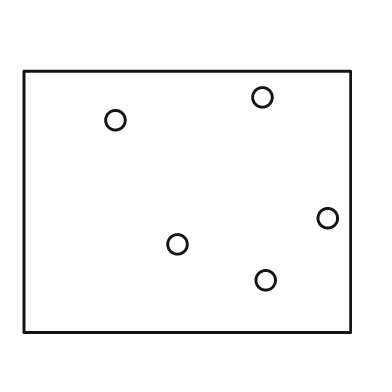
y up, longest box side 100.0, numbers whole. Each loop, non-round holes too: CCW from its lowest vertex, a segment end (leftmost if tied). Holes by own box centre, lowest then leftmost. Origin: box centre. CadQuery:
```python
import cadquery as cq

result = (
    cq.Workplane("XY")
    .moveTo(-50.0, -40.0)
    .lineTo(50.0, -40.0)
    .lineTo(50.0, 40.0)
    .lineTo(-50.0, 40.0)
    .close()
    .moveTo(24.0, -24.0)
    .circle(3.0)
    .moveTo(-3.0, -13.0)
    .circle(3.0)
    .moveTo(43.0, -5.0)
    .circle(3.0)
    .moveTo(-22.0, 25.0)
    .circle(3.0)
    .moveTo(23.0, 32.0)
    .circle(3.0)
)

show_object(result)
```